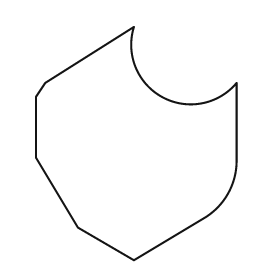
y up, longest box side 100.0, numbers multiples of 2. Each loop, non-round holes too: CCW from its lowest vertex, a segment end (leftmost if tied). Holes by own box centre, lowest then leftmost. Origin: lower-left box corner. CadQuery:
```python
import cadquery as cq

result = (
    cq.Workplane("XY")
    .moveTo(42.0, 0.0)
    .lineTo(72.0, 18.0)
    .threePointArc((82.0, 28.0), (86.0, 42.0))
    .lineTo(86.0, 76.0)
    .threePointArc((54.0, 70.0), (42.0, 100.0))
    .lineTo(4.0, 76.0)
    .lineTo(0.0, 70.0)
    .lineTo(0.0, 44.0)
    .lineTo(18.0, 14.0)
    .close()
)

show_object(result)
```